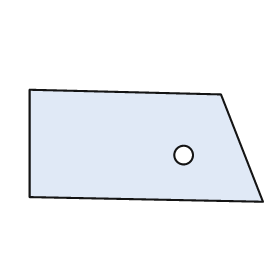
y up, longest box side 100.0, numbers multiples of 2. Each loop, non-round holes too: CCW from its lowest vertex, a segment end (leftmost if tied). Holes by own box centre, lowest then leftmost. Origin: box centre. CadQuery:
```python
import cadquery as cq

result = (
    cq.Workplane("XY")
    .moveTo(50.0, -24.0)
    .lineTo(32.0, 22.0)
    .lineTo(-50.0, 24.0)
    .lineTo(-50.0, -22.0)
    .close()
    .moveTo(16.0, -4.0)
    .circle(4.0)
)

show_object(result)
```